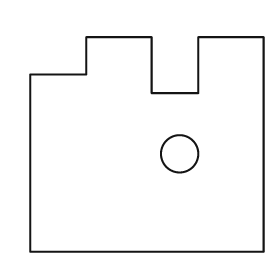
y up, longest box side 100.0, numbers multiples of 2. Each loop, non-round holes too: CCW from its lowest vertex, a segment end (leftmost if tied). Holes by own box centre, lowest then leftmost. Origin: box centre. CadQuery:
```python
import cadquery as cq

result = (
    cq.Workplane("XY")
    .moveTo(-50.0, -46.0)
    .lineTo(50.0, -46.0)
    .lineTo(50.0, 46.0)
    .lineTo(22.0, 46.0)
    .lineTo(22.0, 22.0)
    .lineTo(2.0, 22.0)
    .lineTo(2.0, 46.0)
    .lineTo(-26.0, 46.0)
    .lineTo(-26.0, 30.0)
    .lineTo(-50.0, 30.0)
    .close()
    .moveTo(14.0, -4.0)
    .circle(8.0)
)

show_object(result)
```